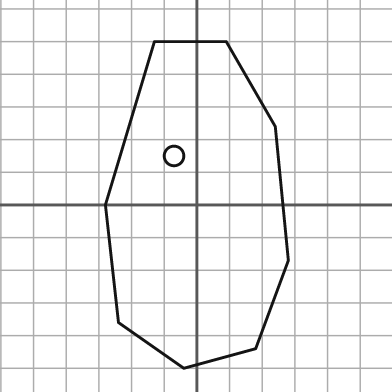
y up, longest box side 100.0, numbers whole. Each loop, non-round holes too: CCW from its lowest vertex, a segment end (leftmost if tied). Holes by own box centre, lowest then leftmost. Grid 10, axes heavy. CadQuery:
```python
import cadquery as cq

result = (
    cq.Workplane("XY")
    .moveTo(-4.0, -50.0)
    .lineTo(18.0, -44.0)
    .lineTo(28.0, -17.0)
    .lineTo(24.0, 24.0)
    .lineTo(9.0, 50.0)
    .lineTo(-13.0, 50.0)
    .lineTo(-28.0, 0.0)
    .lineTo(-24.0, -36.0)
    .close()
    .moveTo(-7.0, 15.0)
    .circle(3.0)
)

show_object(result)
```